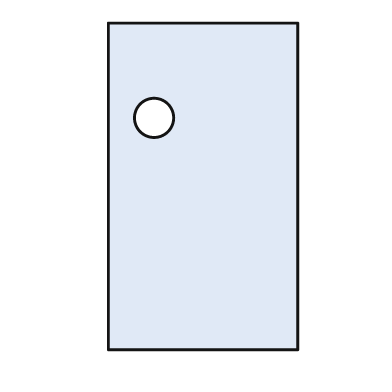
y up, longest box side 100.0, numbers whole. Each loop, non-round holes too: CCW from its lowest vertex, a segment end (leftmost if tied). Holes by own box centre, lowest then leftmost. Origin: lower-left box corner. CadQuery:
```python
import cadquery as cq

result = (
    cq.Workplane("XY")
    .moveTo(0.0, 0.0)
    .lineTo(58.0, 0.0)
    .lineTo(58.0, 100.0)
    .lineTo(0.0, 100.0)
    .close()
    .moveTo(14.0, 71.0)
    .circle(6.0)
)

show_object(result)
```